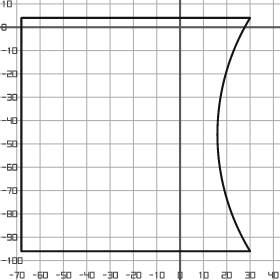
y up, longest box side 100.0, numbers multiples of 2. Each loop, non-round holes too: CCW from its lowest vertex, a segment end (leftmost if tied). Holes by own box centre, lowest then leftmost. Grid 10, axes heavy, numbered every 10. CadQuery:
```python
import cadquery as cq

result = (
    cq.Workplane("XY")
    .moveTo(-68.0, -96.0)
    .lineTo(30.0, -96.0)
    .threePointArc((16.0, -46.0), (30.0, 4.0))
    .lineTo(-68.0, 4.0)
    .close()
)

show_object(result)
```